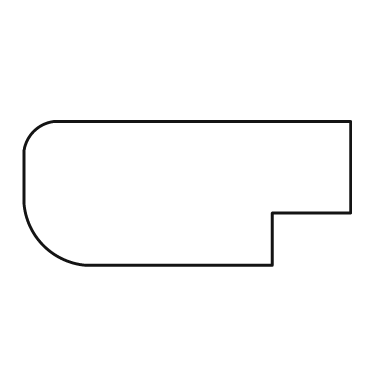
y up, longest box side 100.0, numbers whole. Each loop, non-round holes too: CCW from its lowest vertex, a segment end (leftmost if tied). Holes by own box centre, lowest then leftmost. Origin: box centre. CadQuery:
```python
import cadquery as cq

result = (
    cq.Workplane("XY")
    .moveTo(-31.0, -22.0)
    .lineTo(26.0, -22.0)
    .lineTo(26.0, -6.0)
    .lineTo(50.0, -6.0)
    .lineTo(50.0, 22.0)
    .lineTo(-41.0, 22.0)
    .threePointArc((-47.0, 19.0), (-50.0, 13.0))
    .lineTo(-50.0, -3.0)
    .threePointArc((-44.0, -16.0), (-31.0, -22.0))
    .close()
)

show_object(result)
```